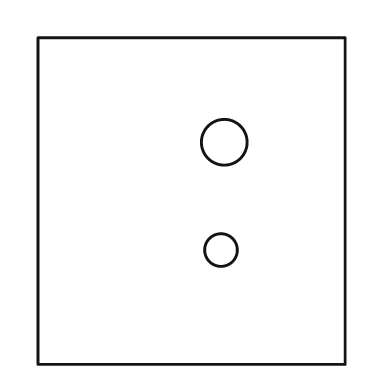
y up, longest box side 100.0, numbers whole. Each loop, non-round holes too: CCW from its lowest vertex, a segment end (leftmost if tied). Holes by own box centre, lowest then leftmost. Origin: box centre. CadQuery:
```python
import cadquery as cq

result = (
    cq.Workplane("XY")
    .moveTo(-47.0, -50.0)
    .lineTo(47.0, -50.0)
    .lineTo(47.0, 50.0)
    .lineTo(-47.0, 50.0)
    .close()
    .moveTo(9.0, -15.0)
    .circle(5.0)
    .moveTo(10.0, 18.0)
    .circle(7.0)
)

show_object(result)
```